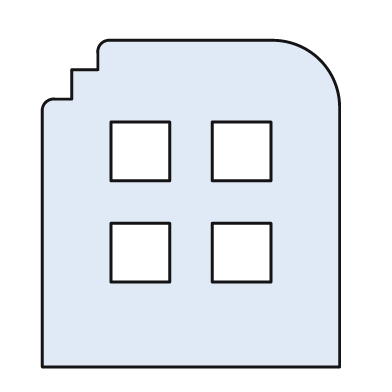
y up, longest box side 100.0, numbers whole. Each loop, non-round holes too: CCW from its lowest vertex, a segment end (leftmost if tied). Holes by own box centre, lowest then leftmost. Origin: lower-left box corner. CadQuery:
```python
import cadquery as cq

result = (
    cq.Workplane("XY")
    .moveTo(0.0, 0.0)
    .lineTo(91.0, 0.0)
    .lineTo(91.0, 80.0)
    .threePointArc((85.0, 94.0), (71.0, 100.0))
    .lineTo(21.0, 100.0)
    .threePointArc((18.0, 99.0), (17.0, 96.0))
    .lineTo(17.0, 91.0)
    .lineTo(9.0, 91.0)
    .lineTo(9.0, 82.0)
    .lineTo(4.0, 82.0)
    .threePointArc((1.0, 81.0), (0.0, 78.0))
    .close()
    .moveTo(21.0, 26.0)
    .lineTo(39.0, 26.0)
    .lineTo(39.0, 44.0)
    .lineTo(21.0, 44.0)
    .close()
    .moveTo(52.0, 26.0)
    .lineTo(70.0, 26.0)
    .lineTo(70.0, 44.0)
    .lineTo(52.0, 44.0)
    .close()
    .moveTo(21.0, 57.0)
    .lineTo(39.0, 57.0)
    .lineTo(39.0, 75.0)
    .lineTo(21.0, 75.0)
    .close()
    .moveTo(52.0, 57.0)
    .lineTo(70.0, 57.0)
    .lineTo(70.0, 75.0)
    .lineTo(52.0, 75.0)
    .close()
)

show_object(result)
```